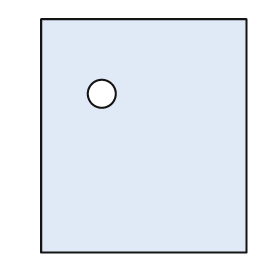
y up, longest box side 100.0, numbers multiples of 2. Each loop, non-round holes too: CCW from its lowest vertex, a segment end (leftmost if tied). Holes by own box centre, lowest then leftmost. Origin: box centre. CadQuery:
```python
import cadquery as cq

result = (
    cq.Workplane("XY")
    .moveTo(-44.0, -50.0)
    .lineTo(44.0, -50.0)
    .lineTo(44.0, 50.0)
    .lineTo(-44.0, 50.0)
    .close()
    .moveTo(-18.0, 18.0)
    .circle(6.0)
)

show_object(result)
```